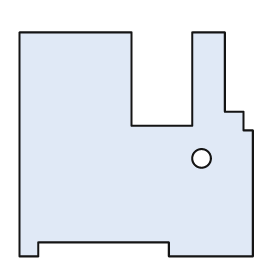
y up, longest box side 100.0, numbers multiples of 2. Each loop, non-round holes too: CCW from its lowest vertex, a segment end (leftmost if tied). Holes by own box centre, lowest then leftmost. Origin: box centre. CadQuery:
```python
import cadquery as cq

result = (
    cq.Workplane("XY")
    .moveTo(-50.0, -48.0)
    .lineTo(-42.0, -48.0)
    .lineTo(-42.0, -42.0)
    .lineTo(14.0, -42.0)
    .lineTo(14.0, -48.0)
    .lineTo(50.0, -48.0)
    .lineTo(50.0, 6.0)
    .lineTo(46.0, 6.0)
    .lineTo(46.0, 14.0)
    .lineTo(38.0, 14.0)
    .lineTo(38.0, 48.0)
    .lineTo(24.0, 48.0)
    .lineTo(24.0, 8.0)
    .lineTo(-2.0, 8.0)
    .lineTo(-2.0, 48.0)
    .lineTo(-50.0, 48.0)
    .close()
    .moveTo(28.0, -6.0)
    .circle(4.0)
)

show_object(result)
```